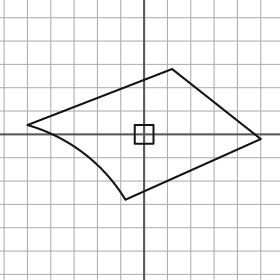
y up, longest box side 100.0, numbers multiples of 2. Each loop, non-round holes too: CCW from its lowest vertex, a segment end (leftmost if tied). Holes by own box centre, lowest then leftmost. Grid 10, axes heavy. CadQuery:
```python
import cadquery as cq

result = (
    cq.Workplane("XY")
    .moveTo(-8.0, -28.0)
    .lineTo(50.0, -2.0)
    .lineTo(12.0, 28.0)
    .lineTo(-50.0, 4.0)
    .threePointArc((-26.0, -8.0), (-8.0, -28.0))
    .close()
    .moveTo(-4.0, -4.0)
    .lineTo(4.0, -4.0)
    .lineTo(4.0, 4.0)
    .lineTo(-4.0, 4.0)
    .close()
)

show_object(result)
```